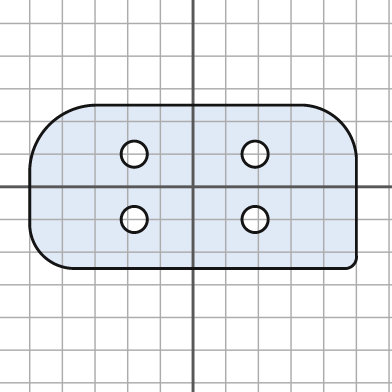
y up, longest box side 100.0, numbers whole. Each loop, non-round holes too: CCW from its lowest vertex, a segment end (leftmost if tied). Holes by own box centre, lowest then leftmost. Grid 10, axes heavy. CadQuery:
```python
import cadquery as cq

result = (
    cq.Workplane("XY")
    .moveTo(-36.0, -25.0)
    .lineTo(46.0, -25.0)
    .threePointArc((49.0, -24.0), (50.0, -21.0))
    .lineTo(50.0, 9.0)
    .threePointArc((45.0, 20.0), (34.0, 25.0))
    .lineTo(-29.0, 25.0)
    .threePointArc((-44.0, 19.0), (-50.0, 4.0))
    .lineTo(-50.0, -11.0)
    .threePointArc((-46.0, -21.0), (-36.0, -25.0))
    .close()
    .moveTo(-18.0, -10.0)
    .circle(4.0)
    .moveTo(19.0, -10.0)
    .circle(4.0)
    .moveTo(-18.0, 10.0)
    .circle(4.0)
    .moveTo(19.0, 10.0)
    .circle(4.0)
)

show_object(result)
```